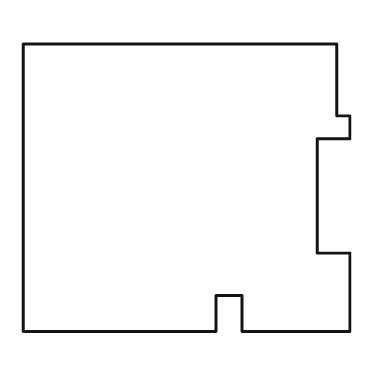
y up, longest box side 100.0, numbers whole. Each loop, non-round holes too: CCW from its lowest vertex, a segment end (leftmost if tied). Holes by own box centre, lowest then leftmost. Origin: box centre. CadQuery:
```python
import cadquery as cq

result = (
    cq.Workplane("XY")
    .moveTo(-50.0, -44.0)
    .lineTo(9.0, -44.0)
    .lineTo(9.0, -33.0)
    .lineTo(17.0, -33.0)
    .lineTo(17.0, -44.0)
    .lineTo(50.0, -44.0)
    .lineTo(50.0, -20.0)
    .lineTo(40.0, -20.0)
    .lineTo(40.0, 15.0)
    .lineTo(50.0, 15.0)
    .lineTo(50.0, 22.0)
    .lineTo(46.0, 22.0)
    .lineTo(46.0, 44.0)
    .lineTo(-50.0, 44.0)
    .close()
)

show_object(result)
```